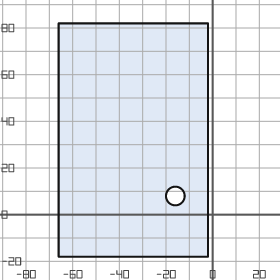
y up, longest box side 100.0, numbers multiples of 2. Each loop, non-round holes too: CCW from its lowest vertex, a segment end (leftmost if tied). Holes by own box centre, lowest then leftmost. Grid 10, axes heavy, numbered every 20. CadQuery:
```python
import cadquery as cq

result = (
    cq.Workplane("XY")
    .moveTo(-66.0, -18.0)
    .lineTo(-2.0, -18.0)
    .lineTo(-2.0, 82.0)
    .lineTo(-66.0, 82.0)
    .close()
    .moveTo(-16.0, 8.0)
    .circle(4.0)
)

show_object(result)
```